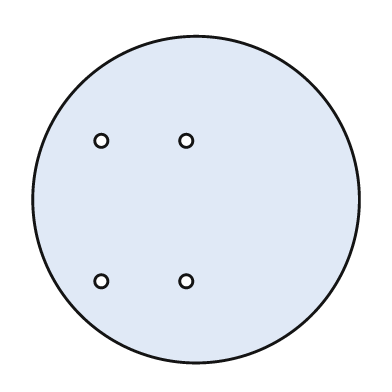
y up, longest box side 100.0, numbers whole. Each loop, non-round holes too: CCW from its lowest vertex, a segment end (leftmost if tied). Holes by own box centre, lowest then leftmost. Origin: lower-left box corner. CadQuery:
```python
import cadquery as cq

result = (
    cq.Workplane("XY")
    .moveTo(50.0, 50.0)
    .circle(50.0)
    .moveTo(21.0, 25.0)
    .circle(2.0)
    .moveTo(47.0, 25.0)
    .circle(2.0)
    .moveTo(21.0, 68.0)
    .circle(2.0)
    .moveTo(47.0, 68.0)
    .circle(2.0)
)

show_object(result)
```